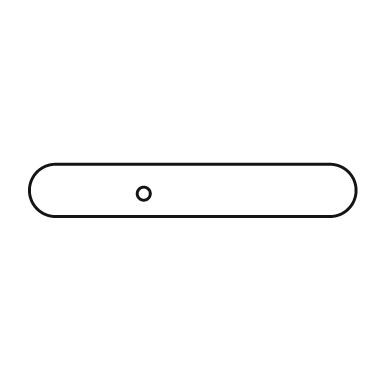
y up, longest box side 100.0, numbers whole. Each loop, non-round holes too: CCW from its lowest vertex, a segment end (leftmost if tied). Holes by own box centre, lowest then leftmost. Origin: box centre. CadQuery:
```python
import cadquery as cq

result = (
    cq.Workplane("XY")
    .moveTo(-42.0, -8.0)
    .lineTo(42.0, -8.0)
    .threePointArc((50.0, 0.0), (42.0, 8.0))
    .lineTo(-42.0, 8.0)
    .threePointArc((-50.0, 0.0), (-42.0, -8.0))
    .close()
    .moveTo(-15.0, -1.0)
    .circle(2.0)
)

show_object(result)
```